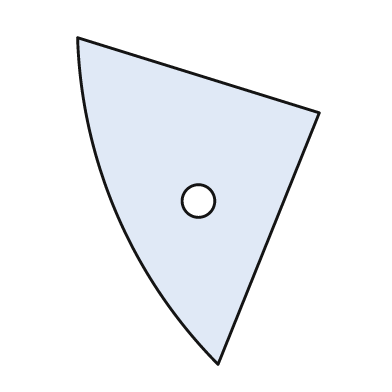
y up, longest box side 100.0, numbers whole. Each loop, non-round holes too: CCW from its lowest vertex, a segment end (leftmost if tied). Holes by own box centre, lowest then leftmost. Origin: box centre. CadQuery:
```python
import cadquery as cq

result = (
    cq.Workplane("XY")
    .moveTo(6.0, -50.0)
    .lineTo(37.0, 27.0)
    .lineTo(-37.0, 50.0)
    .threePointArc((-25.0, -4.0), (6.0, -50.0))
    .close()
    .moveTo(0.0, 0.0)
    .circle(5.0)
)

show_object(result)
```